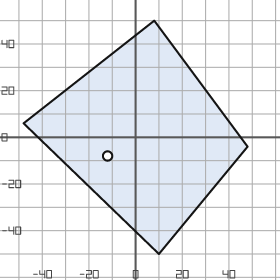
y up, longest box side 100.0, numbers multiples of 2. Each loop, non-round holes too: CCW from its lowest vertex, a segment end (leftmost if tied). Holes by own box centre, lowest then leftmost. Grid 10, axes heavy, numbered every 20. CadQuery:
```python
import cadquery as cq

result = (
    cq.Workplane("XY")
    .moveTo(10.0, -50.0)
    .lineTo(48.0, -4.0)
    .lineTo(8.0, 50.0)
    .lineTo(-48.0, 6.0)
    .close()
    .moveTo(-12.0, -8.0)
    .circle(2.0)
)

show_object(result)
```